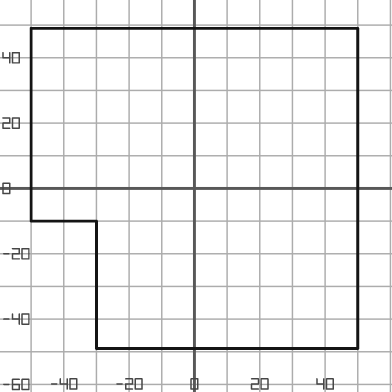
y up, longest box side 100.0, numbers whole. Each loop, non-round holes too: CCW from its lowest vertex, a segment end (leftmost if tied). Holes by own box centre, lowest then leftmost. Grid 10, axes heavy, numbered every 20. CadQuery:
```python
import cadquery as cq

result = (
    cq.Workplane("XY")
    .moveTo(-30.0, -49.0)
    .lineTo(50.0, -49.0)
    .lineTo(50.0, 49.0)
    .lineTo(-50.0, 49.0)
    .lineTo(-50.0, -10.0)
    .lineTo(-30.0, -10.0)
    .close()
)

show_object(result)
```